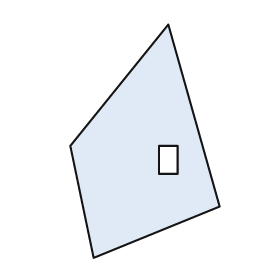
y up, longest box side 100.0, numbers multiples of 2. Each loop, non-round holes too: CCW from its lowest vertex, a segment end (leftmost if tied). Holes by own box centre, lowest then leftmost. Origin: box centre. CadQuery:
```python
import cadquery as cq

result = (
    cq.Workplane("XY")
    .moveTo(-22.0, -50.0)
    .lineTo(32.0, -28.0)
    .lineTo(10.0, 50.0)
    .lineTo(-32.0, -2.0)
    .close()
    .moveTo(6.0, -14.0)
    .lineTo(14.0, -14.0)
    .lineTo(14.0, -2.0)
    .lineTo(6.0, -2.0)
    .close()
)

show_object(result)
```